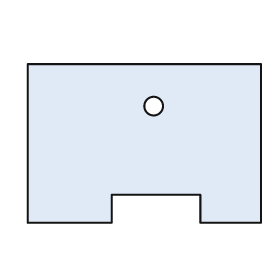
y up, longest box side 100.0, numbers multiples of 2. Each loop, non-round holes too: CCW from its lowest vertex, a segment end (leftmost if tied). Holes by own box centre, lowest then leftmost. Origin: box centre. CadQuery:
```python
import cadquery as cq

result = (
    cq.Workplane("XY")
    .moveTo(-50.0, -34.0)
    .lineTo(-14.0, -34.0)
    .lineTo(-14.0, -22.0)
    .lineTo(24.0, -22.0)
    .lineTo(24.0, -34.0)
    .lineTo(50.0, -34.0)
    .lineTo(50.0, 34.0)
    .lineTo(-50.0, 34.0)
    .close()
    .moveTo(4.0, 16.0)
    .circle(4.0)
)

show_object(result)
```